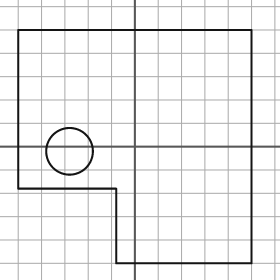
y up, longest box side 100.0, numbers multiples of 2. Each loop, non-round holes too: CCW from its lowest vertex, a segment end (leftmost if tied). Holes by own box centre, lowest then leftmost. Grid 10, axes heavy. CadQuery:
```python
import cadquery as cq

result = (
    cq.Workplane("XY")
    .moveTo(-8.0, -50.0)
    .lineTo(50.0, -50.0)
    .lineTo(50.0, 50.0)
    .lineTo(-50.0, 50.0)
    .lineTo(-50.0, -18.0)
    .lineTo(-8.0, -18.0)
    .close()
    .moveTo(-28.0, -2.0)
    .circle(10.0)
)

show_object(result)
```